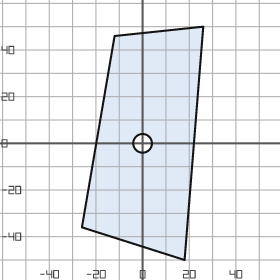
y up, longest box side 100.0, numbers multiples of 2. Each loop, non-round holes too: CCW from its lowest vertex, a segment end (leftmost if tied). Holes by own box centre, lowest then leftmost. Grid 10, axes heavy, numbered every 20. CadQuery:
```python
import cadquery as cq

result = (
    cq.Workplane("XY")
    .moveTo(18.0, -50.0)
    .lineTo(26.0, 50.0)
    .lineTo(-12.0, 46.0)
    .lineTo(-26.0, -36.0)
    .close()
    .moveTo(0.0, 0.0)
    .circle(4.0)
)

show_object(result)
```